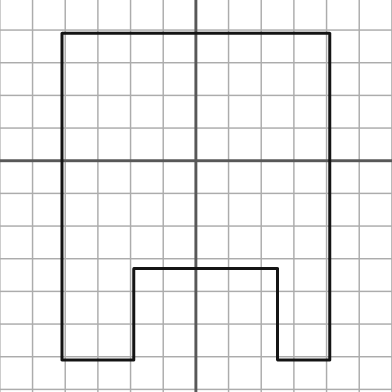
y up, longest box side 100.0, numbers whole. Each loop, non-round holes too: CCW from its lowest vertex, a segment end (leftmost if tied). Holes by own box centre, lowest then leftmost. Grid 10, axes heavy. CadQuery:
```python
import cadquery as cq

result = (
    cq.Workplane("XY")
    .moveTo(-41.0, -61.0)
    .lineTo(-19.0, -61.0)
    .lineTo(-19.0, -33.0)
    .lineTo(25.0, -33.0)
    .lineTo(25.0, -61.0)
    .lineTo(41.0, -61.0)
    .lineTo(41.0, 39.0)
    .lineTo(-41.0, 39.0)
    .close()
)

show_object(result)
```